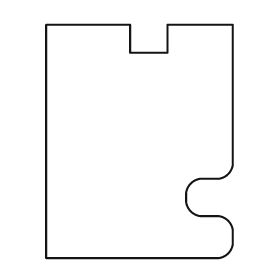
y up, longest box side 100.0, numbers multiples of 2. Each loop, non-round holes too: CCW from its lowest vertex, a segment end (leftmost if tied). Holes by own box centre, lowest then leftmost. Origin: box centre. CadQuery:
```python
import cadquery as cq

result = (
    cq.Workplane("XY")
    .moveTo(-40.0, -50.0)
    .lineTo(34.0, -50.0)
    .threePointArc((38.0, -48.0), (40.0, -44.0))
    .lineTo(40.0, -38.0)
    .threePointArc((38.0, -34.0), (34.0, -32.0))
    .lineTo(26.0, -32.0)
    .threePointArc((22.0, -30.0), (20.0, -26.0))
    .lineTo(20.0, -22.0)
    .threePointArc((22.0, -18.0), (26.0, -16.0))
    .lineTo(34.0, -16.0)
    .threePointArc((38.0, -14.0), (40.0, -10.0))
    .lineTo(40.0, 50.0)
    .lineTo(12.0, 50.0)
    .lineTo(12.0, 38.0)
    .lineTo(-4.0, 38.0)
    .lineTo(-4.0, 50.0)
    .lineTo(-40.0, 50.0)
    .close()
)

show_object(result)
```